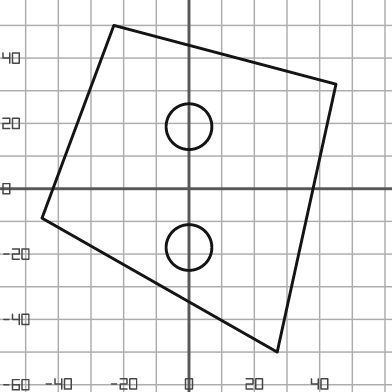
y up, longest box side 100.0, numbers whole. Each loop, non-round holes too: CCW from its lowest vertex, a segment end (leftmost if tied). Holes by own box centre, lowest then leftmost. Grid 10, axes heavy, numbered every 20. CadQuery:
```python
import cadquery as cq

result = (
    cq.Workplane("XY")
    .moveTo(27.0, -50.0)
    .lineTo(45.0, 32.0)
    .lineTo(-23.0, 50.0)
    .lineTo(-45.0, -9.0)
    .close()
    .moveTo(0.0, -18.0)
    .circle(7.0)
    .moveTo(0.0, 19.0)
    .circle(7.0)
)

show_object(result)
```